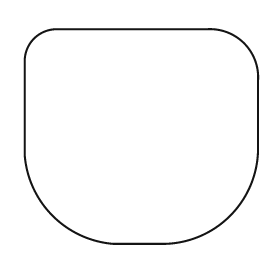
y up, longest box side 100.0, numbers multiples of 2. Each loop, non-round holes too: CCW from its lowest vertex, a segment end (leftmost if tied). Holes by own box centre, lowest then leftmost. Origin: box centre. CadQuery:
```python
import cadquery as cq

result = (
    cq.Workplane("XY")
    .moveTo(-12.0, -46.0)
    .lineTo(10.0, -46.0)
    .threePointArc((38.0, -34.0), (50.0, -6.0))
    .lineTo(50.0, 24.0)
    .threePointArc((44.0, 40.0), (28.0, 46.0))
    .lineTo(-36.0, 46.0)
    .threePointArc((-46.0, 42.0), (-50.0, 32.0))
    .lineTo(-50.0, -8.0)
    .threePointArc((-38.0, -34.0), (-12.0, -46.0))
    .close()
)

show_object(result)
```